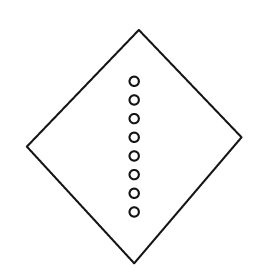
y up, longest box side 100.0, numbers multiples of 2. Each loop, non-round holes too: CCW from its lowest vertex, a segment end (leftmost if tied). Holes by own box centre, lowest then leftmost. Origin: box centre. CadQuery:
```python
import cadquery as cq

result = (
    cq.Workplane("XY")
    .moveTo(0.0, -50.0)
    .lineTo(46.0, 4.0)
    .lineTo(2.0, 50.0)
    .lineTo(-46.0, 0.0)
    .close()
    .moveTo(0.0, -28.0)
    .circle(2.0)
    .moveTo(0.0, -20.0)
    .circle(2.0)
    .moveTo(0.0, -12.0)
    .circle(2.0)
    .moveTo(0.0, -4.0)
    .circle(2.0)
    .moveTo(0.0, 4.0)
    .circle(2.0)
    .moveTo(0.0, 12.0)
    .circle(2.0)
    .moveTo(0.0, 20.0)
    .circle(2.0)
    .moveTo(0.0, 28.0)
    .circle(2.0)
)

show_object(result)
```